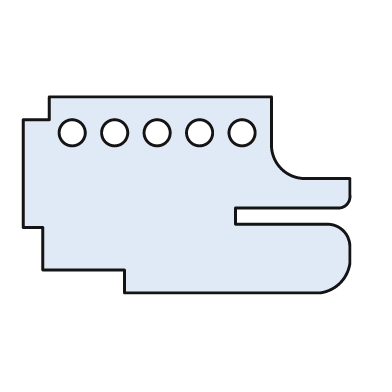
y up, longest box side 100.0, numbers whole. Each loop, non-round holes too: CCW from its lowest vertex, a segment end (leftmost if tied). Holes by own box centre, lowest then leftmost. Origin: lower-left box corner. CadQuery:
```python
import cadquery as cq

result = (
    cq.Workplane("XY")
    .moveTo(31.0, 0.0)
    .lineTo(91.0, 0.0)
    .threePointArc((97.0, 3.0), (100.0, 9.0))
    .lineTo(100.0, 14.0)
    .threePointArc((98.0, 19.0), (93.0, 21.0))
    .lineTo(65.0, 21.0)
    .lineTo(65.0, 26.0)
    .lineTo(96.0, 26.0)
    .threePointArc((99.0, 27.0), (100.0, 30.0))
    .lineTo(100.0, 35.0)
    .lineTo(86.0, 35.0)
    .threePointArc((79.0, 38.0), (76.0, 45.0))
    .lineTo(76.0, 60.0)
    .lineTo(8.0, 60.0)
    .lineTo(8.0, 53.0)
    .lineTo(0.0, 53.0)
    .lineTo(0.0, 20.0)
    .lineTo(6.0, 20.0)
    .lineTo(6.0, 7.0)
    .lineTo(31.0, 7.0)
    .close()
    .moveTo(15.0, 49.0)
    .circle(4.0)
    .moveTo(28.0, 49.0)
    .circle(4.0)
    .moveTo(41.0, 49.0)
    .circle(4.0)
    .moveTo(54.0, 49.0)
    .circle(4.0)
    .moveTo(67.0, 49.0)
    .circle(4.0)
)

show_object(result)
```